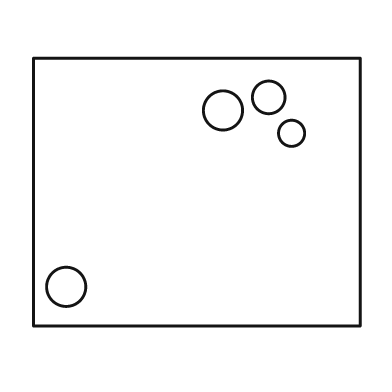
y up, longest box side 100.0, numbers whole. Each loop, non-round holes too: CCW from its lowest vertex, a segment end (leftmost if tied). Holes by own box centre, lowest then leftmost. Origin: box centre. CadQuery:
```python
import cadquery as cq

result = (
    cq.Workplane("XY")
    .moveTo(-50.0, -41.0)
    .lineTo(50.0, -41.0)
    .lineTo(50.0, 41.0)
    .lineTo(-50.0, 41.0)
    .close()
    .moveTo(-40.0, -29.0)
    .circle(6.0)
    .moveTo(29.0, 18.0)
    .circle(4.0)
    .moveTo(8.0, 25.0)
    .circle(6.0)
    .moveTo(22.0, 29.0)
    .circle(5.0)
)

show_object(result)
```